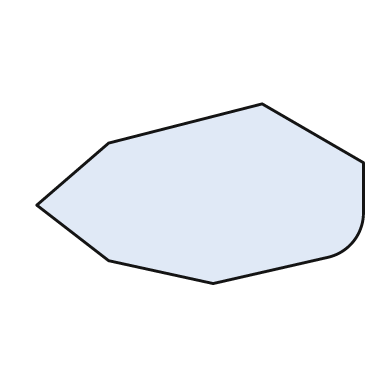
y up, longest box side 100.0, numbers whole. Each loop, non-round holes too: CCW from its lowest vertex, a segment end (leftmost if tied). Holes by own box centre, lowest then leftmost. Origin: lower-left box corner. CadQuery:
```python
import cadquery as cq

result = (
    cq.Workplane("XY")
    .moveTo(54.0, 0.0)
    .lineTo(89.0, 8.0)
    .threePointArc((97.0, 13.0), (100.0, 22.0))
    .lineTo(100.0, 37.0)
    .lineTo(69.0, 55.0)
    .lineTo(22.0, 43.0)
    .lineTo(0.0, 24.0)
    .lineTo(22.0, 7.0)
    .close()
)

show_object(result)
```